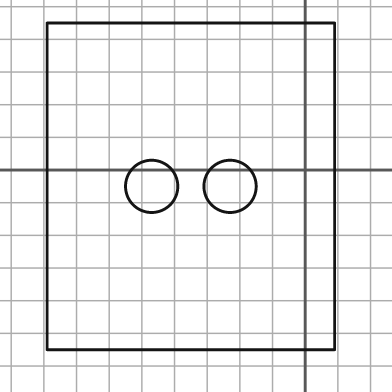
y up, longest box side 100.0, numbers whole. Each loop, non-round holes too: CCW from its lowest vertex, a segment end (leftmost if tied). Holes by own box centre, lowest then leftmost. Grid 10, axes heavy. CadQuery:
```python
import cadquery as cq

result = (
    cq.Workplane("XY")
    .moveTo(-79.0, -55.0)
    .lineTo(9.0, -55.0)
    .lineTo(9.0, 45.0)
    .lineTo(-79.0, 45.0)
    .close()
    .moveTo(-47.0, -5.0)
    .circle(8.0)
    .moveTo(-23.0, -5.0)
    .circle(8.0)
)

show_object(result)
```